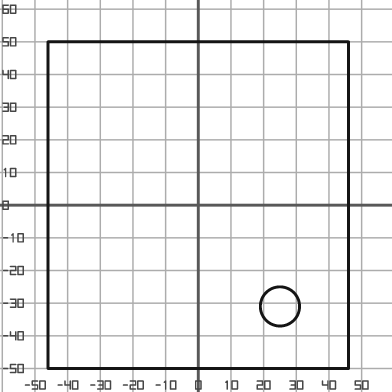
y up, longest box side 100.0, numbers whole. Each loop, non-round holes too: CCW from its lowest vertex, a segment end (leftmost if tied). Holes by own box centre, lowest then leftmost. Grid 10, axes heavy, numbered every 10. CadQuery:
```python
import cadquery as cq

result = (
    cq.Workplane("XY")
    .moveTo(-46.0, -50.0)
    .lineTo(46.0, -50.0)
    .lineTo(46.0, 50.0)
    .lineTo(-46.0, 50.0)
    .close()
    .moveTo(25.0, -31.0)
    .circle(6.0)
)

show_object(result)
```